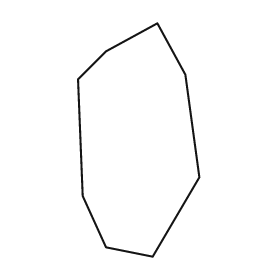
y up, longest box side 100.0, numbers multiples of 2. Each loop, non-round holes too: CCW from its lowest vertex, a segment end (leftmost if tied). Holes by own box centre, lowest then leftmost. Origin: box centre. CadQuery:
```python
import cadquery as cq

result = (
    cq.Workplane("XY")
    .moveTo(6.0, -50.0)
    .lineTo(26.0, -16.0)
    .lineTo(20.0, 28.0)
    .lineTo(8.0, 50.0)
    .lineTo(-14.0, 38.0)
    .lineTo(-26.0, 26.0)
    .lineTo(-24.0, -24.0)
    .lineTo(-14.0, -46.0)
    .close()
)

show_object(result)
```